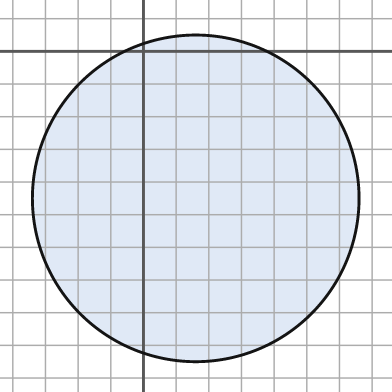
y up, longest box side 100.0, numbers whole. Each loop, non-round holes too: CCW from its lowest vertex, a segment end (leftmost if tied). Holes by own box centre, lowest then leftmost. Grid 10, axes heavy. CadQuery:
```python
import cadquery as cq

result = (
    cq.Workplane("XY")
    .moveTo(16.0, -45.0)
    .circle(50.0)
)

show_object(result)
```